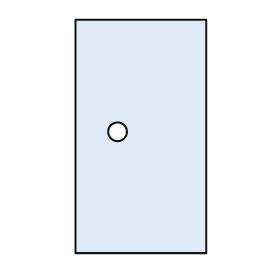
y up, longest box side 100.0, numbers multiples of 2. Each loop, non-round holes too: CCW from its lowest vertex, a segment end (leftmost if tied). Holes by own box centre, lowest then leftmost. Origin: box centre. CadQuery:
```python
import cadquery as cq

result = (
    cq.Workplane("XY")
    .moveTo(-28.0, -50.0)
    .lineTo(28.0, -50.0)
    .lineTo(28.0, 50.0)
    .lineTo(-28.0, 50.0)
    .close()
    .moveTo(-10.0, 2.0)
    .circle(4.0)
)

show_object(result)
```